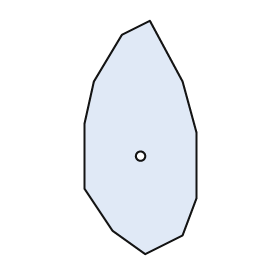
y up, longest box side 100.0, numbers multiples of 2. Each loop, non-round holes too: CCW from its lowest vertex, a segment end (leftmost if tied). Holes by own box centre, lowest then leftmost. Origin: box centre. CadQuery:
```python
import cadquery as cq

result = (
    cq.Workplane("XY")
    .moveTo(2.0, -50.0)
    .lineTo(18.0, -42.0)
    .lineTo(24.0, -26.0)
    .lineTo(24.0, 2.0)
    .lineTo(18.0, 24.0)
    .lineTo(4.0, 50.0)
    .lineTo(-8.0, 44.0)
    .lineTo(-20.0, 24.0)
    .lineTo(-24.0, 6.0)
    .lineTo(-24.0, -22.0)
    .lineTo(-12.0, -40.0)
    .close()
    .moveTo(0.0, -8.0)
    .circle(2.0)
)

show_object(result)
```